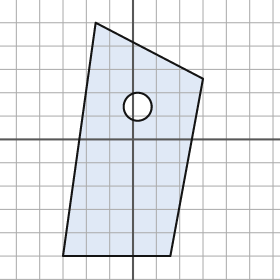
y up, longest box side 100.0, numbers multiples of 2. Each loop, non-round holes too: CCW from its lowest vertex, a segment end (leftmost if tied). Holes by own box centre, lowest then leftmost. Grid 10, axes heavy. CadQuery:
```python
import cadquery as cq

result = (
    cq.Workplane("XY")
    .moveTo(-30.0, -50.0)
    .lineTo(16.0, -50.0)
    .lineTo(30.0, 26.0)
    .lineTo(-16.0, 50.0)
    .close()
    .moveTo(2.0, 14.0)
    .circle(6.0)
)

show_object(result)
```